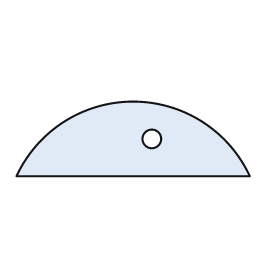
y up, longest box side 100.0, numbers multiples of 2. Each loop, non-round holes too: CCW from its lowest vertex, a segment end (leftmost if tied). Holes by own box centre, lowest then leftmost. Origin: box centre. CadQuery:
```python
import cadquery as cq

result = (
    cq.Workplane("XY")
    .moveTo(-50.0, -16.0)
    .lineTo(50.0, -16.0)
    .threePointArc((0.0, 16.0), (-50.0, -16.0))
    .close()
    .moveTo(8.0, 0.0)
    .circle(4.0)
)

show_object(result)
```